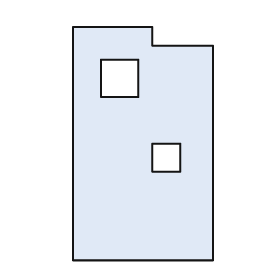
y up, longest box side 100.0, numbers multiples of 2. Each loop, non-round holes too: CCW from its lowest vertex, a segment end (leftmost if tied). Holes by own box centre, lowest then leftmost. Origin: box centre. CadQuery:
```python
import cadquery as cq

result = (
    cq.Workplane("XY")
    .moveTo(-30.0, -50.0)
    .lineTo(30.0, -50.0)
    .lineTo(30.0, 42.0)
    .lineTo(4.0, 42.0)
    .lineTo(4.0, 50.0)
    .lineTo(-30.0, 50.0)
    .close()
    .moveTo(4.0, -12.0)
    .lineTo(16.0, -12.0)
    .lineTo(16.0, 0.0)
    .lineTo(4.0, 0.0)
    .close()
    .moveTo(-18.0, 20.0)
    .lineTo(-2.0, 20.0)
    .lineTo(-2.0, 36.0)
    .lineTo(-18.0, 36.0)
    .close()
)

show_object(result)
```